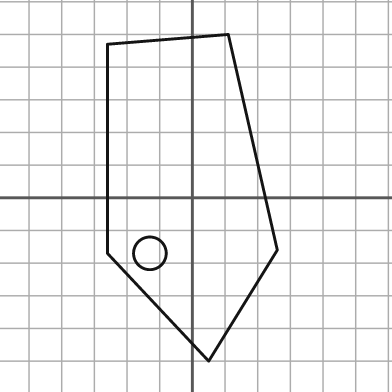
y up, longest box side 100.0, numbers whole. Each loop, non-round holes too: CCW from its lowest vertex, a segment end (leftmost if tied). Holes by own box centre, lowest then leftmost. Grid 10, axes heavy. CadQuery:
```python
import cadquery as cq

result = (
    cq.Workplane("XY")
    .moveTo(5.0, -50.0)
    .lineTo(26.0, -16.0)
    .lineTo(11.0, 50.0)
    .lineTo(-26.0, 47.0)
    .lineTo(-26.0, -17.0)
    .close()
    .moveTo(-13.0, -17.0)
    .circle(5.0)
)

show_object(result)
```